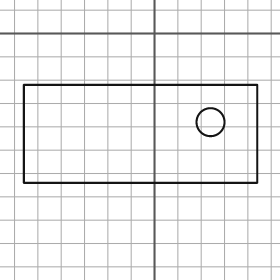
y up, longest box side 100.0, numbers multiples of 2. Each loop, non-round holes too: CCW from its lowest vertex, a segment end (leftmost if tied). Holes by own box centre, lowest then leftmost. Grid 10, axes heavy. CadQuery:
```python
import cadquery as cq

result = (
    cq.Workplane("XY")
    .moveTo(-56.0, -64.0)
    .lineTo(44.0, -64.0)
    .lineTo(44.0, -22.0)
    .lineTo(-56.0, -22.0)
    .close()
    .moveTo(24.0, -38.0)
    .circle(6.0)
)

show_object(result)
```